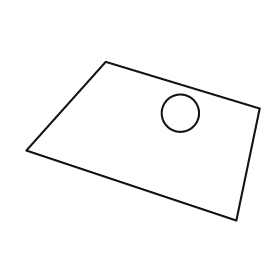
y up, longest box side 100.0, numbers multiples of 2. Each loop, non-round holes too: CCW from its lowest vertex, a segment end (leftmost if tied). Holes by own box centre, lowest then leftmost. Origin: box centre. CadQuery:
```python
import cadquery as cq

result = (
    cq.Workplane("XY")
    .moveTo(40.0, -34.0)
    .lineTo(50.0, 14.0)
    .lineTo(-16.0, 34.0)
    .lineTo(-50.0, -4.0)
    .close()
    .moveTo(16.0, 12.0)
    .circle(8.0)
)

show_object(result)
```